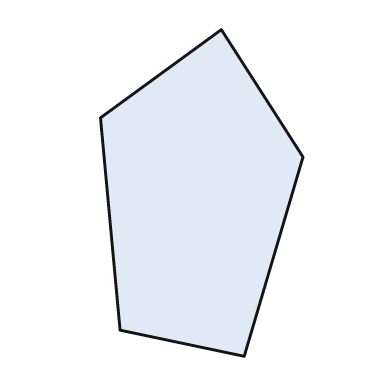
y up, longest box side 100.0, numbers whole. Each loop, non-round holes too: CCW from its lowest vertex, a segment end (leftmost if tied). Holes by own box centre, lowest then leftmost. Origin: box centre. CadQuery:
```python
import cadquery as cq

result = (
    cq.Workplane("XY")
    .moveTo(13.0, -50.0)
    .lineTo(31.0, 11.0)
    .lineTo(6.0, 50.0)
    .lineTo(-31.0, 23.0)
    .lineTo(-25.0, -42.0)
    .close()
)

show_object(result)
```